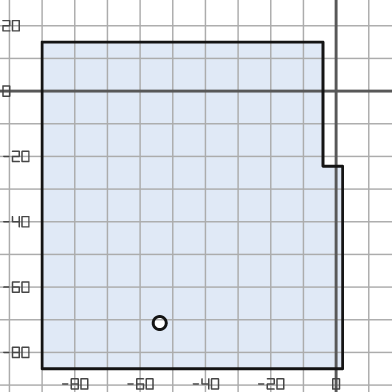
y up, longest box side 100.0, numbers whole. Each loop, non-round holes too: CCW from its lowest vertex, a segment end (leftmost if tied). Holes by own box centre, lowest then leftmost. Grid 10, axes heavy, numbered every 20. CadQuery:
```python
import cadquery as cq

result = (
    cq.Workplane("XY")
    .moveTo(-90.0, -85.0)
    .lineTo(2.0, -85.0)
    .lineTo(2.0, -23.0)
    .lineTo(-4.0, -23.0)
    .lineTo(-4.0, 15.0)
    .lineTo(-90.0, 15.0)
    .close()
    .moveTo(-54.0, -71.0)
    .circle(2.0)
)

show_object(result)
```